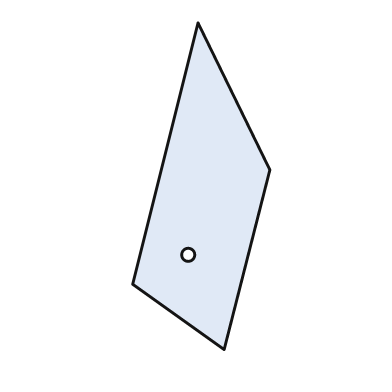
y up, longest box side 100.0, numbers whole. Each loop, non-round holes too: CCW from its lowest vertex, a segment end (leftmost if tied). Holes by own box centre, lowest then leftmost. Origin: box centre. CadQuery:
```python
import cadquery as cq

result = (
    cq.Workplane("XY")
    .moveTo(7.0, -50.0)
    .lineTo(21.0, 5.0)
    .lineTo(-1.0, 50.0)
    .lineTo(-21.0, -30.0)
    .close()
    .moveTo(-4.0, -21.0)
    .circle(2.0)
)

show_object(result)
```